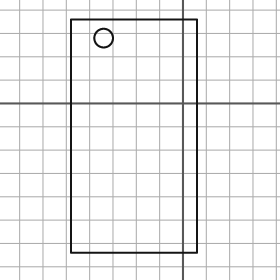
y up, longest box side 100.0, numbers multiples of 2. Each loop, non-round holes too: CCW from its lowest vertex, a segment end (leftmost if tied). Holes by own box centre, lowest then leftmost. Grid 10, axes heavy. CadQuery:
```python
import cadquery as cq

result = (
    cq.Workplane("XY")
    .moveTo(-48.0, -64.0)
    .lineTo(6.0, -64.0)
    .lineTo(6.0, 36.0)
    .lineTo(-48.0, 36.0)
    .close()
    .moveTo(-34.0, 28.0)
    .circle(4.0)
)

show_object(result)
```